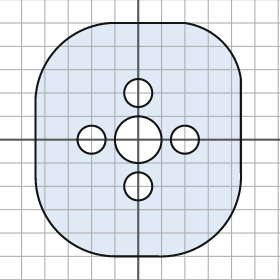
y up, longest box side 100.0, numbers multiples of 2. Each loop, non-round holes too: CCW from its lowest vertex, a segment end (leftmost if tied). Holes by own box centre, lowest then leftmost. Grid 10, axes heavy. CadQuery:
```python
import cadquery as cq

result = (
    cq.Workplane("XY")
    .moveTo(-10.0, -50.0)
    .lineTo(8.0, -50.0)
    .threePointArc((34.0, -40.0), (44.0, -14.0))
    .lineTo(44.0, 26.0)
    .threePointArc((36.0, 42.0), (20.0, 50.0))
    .lineTo(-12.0, 50.0)
    .threePointArc((-34.0, 40.0), (-44.0, 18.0))
    .lineTo(-44.0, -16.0)
    .threePointArc((-34.0, -40.0), (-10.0, -50.0))
    .close()
    .moveTo(0.0, -20.0)
    .circle(6.0)
    .moveTo(-20.0, 0.0)
    .circle(6.0)
    .moveTo(0.0, 0.0)
    .circle(10.0)
    .moveTo(20.0, 0.0)
    .circle(6.0)
    .moveTo(0.0, 20.0)
    .circle(6.0)
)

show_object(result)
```